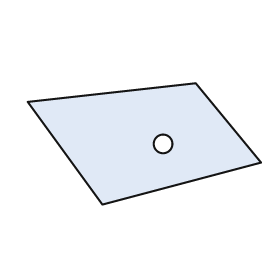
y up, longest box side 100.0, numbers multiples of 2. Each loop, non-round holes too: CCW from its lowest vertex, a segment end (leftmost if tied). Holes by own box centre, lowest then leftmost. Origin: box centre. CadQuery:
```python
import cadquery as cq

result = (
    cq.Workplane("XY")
    .moveTo(-18.0, -26.0)
    .lineTo(50.0, -8.0)
    .lineTo(22.0, 26.0)
    .lineTo(-50.0, 18.0)
    .close()
    .moveTo(8.0, 0.0)
    .circle(4.0)
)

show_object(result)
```